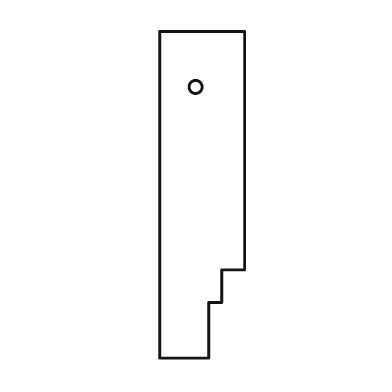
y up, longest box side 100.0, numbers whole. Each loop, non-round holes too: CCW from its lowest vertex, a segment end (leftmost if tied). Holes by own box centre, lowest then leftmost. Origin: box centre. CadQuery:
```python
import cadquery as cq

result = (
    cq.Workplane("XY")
    .moveTo(-13.0, -50.0)
    .lineTo(2.0, -50.0)
    .lineTo(2.0, -33.0)
    .lineTo(6.0, -33.0)
    .lineTo(6.0, -23.0)
    .lineTo(13.0, -23.0)
    .lineTo(13.0, 50.0)
    .lineTo(-13.0, 50.0)
    .close()
    .moveTo(-2.0, 33.0)
    .circle(2.0)
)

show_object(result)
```